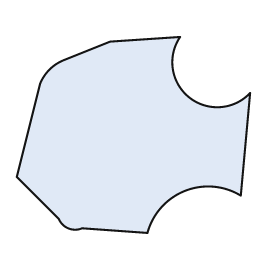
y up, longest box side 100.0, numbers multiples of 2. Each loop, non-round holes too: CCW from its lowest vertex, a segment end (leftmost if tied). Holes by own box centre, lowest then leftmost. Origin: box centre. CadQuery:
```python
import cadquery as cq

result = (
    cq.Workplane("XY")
    .moveTo(6.0, -42.0)
    .threePointArc((22.0, -24.0), (46.0, -26.0))
    .lineTo(50.0, 18.0)
    .threePointArc((24.0, 16.0), (20.0, 42.0))
    .lineTo(-10.0, 40.0)
    .lineTo(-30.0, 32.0)
    .threePointArc((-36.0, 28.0), (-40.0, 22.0))
    .lineTo(-50.0, -18.0)
    .lineTo(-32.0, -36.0)
    .threePointArc((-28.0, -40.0), (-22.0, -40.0))
    .close()
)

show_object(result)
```